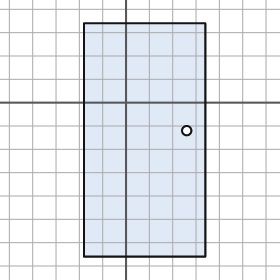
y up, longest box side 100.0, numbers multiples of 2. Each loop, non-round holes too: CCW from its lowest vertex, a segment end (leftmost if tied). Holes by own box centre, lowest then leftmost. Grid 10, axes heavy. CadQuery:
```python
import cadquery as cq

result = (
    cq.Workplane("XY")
    .moveTo(-18.0, -66.0)
    .lineTo(34.0, -66.0)
    .lineTo(34.0, 34.0)
    .lineTo(-18.0, 34.0)
    .close()
    .moveTo(26.0, -12.0)
    .circle(2.0)
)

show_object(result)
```